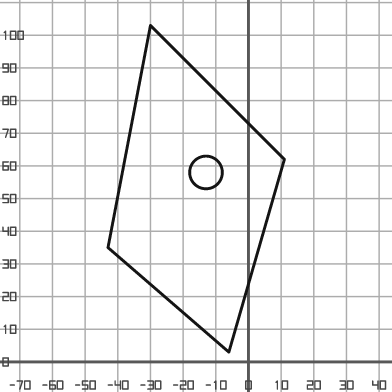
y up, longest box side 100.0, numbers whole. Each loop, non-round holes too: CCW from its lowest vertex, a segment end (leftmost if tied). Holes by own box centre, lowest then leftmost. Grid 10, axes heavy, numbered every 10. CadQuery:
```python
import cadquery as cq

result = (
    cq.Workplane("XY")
    .moveTo(-6.0, 3.0)
    .lineTo(11.0, 62.0)
    .lineTo(-30.0, 103.0)
    .lineTo(-43.0, 35.0)
    .close()
    .moveTo(-13.0, 58.0)
    .circle(5.0)
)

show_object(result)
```